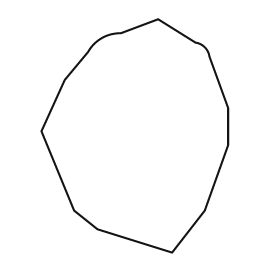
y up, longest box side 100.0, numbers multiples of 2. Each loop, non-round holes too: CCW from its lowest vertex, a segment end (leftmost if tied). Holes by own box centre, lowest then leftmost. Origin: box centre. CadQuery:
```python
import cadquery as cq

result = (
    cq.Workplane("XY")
    .moveTo(16.0, -50.0)
    .lineTo(30.0, -32.0)
    .lineTo(40.0, -4.0)
    .lineTo(40.0, 12.0)
    .lineTo(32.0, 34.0)
    .threePointArc((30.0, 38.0), (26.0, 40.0))
    .lineTo(10.0, 50.0)
    .lineTo(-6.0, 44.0)
    .threePointArc((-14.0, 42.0), (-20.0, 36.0))
    .lineTo(-30.0, 24.0)
    .lineTo(-40.0, 2.0)
    .lineTo(-26.0, -32.0)
    .lineTo(-16.0, -40.0)
    .close()
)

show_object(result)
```